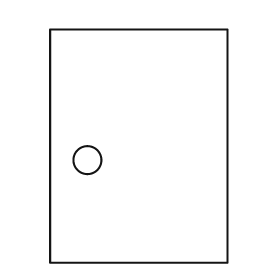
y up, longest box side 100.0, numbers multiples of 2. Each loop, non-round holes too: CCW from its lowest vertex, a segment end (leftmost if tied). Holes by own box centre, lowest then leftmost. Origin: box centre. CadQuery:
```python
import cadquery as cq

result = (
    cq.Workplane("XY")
    .moveTo(-38.0, -50.0)
    .lineTo(38.0, -50.0)
    .lineTo(38.0, 50.0)
    .lineTo(-38.0, 50.0)
    .close()
    .moveTo(-22.0, -6.0)
    .circle(6.0)
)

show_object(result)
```